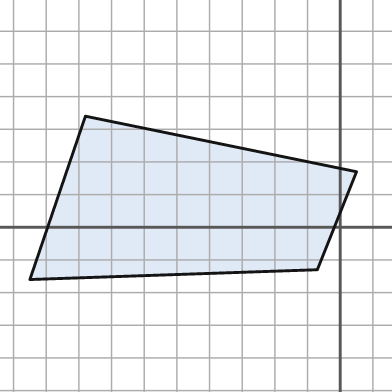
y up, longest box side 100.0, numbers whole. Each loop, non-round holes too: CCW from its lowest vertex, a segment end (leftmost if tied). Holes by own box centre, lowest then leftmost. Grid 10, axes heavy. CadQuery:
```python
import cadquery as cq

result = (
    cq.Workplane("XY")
    .moveTo(-95.0, -16.0)
    .lineTo(-7.0, -13.0)
    .lineTo(5.0, 17.0)
    .lineTo(-78.0, 34.0)
    .close()
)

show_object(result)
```